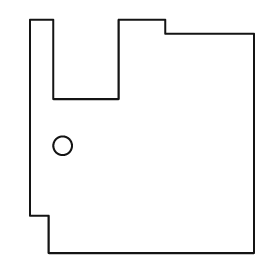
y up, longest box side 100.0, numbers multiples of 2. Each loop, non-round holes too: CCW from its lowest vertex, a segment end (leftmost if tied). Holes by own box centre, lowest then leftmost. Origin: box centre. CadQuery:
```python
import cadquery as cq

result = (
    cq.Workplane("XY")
    .moveTo(-40.0, -50.0)
    .lineTo(48.0, -50.0)
    .lineTo(48.0, 44.0)
    .lineTo(10.0, 44.0)
    .lineTo(10.0, 50.0)
    .lineTo(-10.0, 50.0)
    .lineTo(-10.0, 16.0)
    .lineTo(-38.0, 16.0)
    .lineTo(-38.0, 50.0)
    .lineTo(-48.0, 50.0)
    .lineTo(-48.0, -34.0)
    .lineTo(-40.0, -34.0)
    .close()
    .moveTo(-34.0, -4.0)
    .circle(4.0)
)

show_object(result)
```